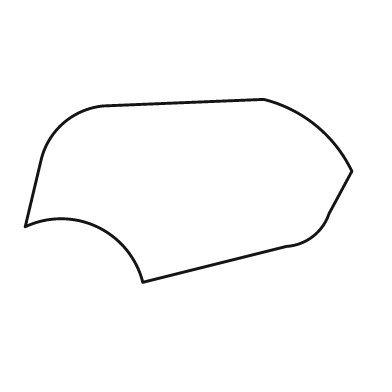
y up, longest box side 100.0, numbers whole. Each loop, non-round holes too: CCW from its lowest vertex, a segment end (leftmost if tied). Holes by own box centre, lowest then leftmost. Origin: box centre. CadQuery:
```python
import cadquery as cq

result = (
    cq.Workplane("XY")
    .moveTo(-14.0, -28.0)
    .lineTo(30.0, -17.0)
    .threePointArc((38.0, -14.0), (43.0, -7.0))
    .lineTo(50.0, 6.0)
    .threePointArc((39.0, 20.0), (23.0, 28.0))
    .lineTo(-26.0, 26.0)
    .threePointArc((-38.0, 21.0), (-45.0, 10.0))
    .lineTo(-50.0, -11.0)
    .threePointArc((-28.0, -11.0), (-14.0, -28.0))
    .close()
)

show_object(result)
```